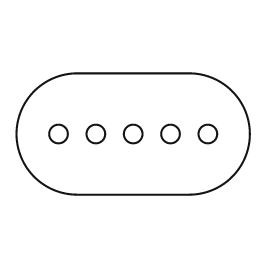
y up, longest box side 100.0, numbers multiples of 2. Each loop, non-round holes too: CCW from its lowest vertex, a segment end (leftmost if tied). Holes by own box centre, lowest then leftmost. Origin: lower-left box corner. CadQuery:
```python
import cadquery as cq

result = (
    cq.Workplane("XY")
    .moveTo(26.0, 0.0)
    .lineTo(74.0, 0.0)
    .threePointArc((100.0, 26.0), (74.0, 52.0))
    .lineTo(26.0, 52.0)
    .threePointArc((0.0, 26.0), (26.0, 0.0))
    .close()
    .moveTo(18.0, 26.0)
    .circle(4.0)
    .moveTo(34.0, 26.0)
    .circle(4.0)
    .moveTo(50.0, 26.0)
    .circle(4.0)
    .moveTo(66.0, 26.0)
    .circle(4.0)
    .moveTo(82.0, 26.0)
    .circle(4.0)
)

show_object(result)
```